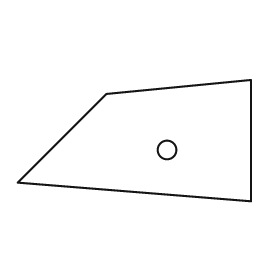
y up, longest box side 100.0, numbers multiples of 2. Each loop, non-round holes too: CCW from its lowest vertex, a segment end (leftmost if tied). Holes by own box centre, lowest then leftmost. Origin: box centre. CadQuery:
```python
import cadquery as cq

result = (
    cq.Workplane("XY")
    .moveTo(50.0, -26.0)
    .lineTo(50.0, 26.0)
    .lineTo(-12.0, 20.0)
    .lineTo(-50.0, -18.0)
    .close()
    .moveTo(14.0, -4.0)
    .circle(4.0)
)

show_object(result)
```